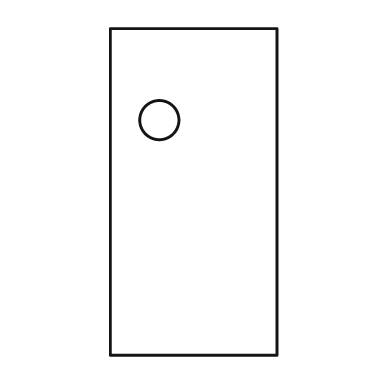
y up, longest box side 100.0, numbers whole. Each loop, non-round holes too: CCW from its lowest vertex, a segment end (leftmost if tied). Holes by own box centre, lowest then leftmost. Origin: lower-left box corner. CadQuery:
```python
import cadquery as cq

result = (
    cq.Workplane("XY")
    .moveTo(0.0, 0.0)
    .lineTo(51.0, 0.0)
    .lineTo(51.0, 100.0)
    .lineTo(0.0, 100.0)
    .close()
    .moveTo(15.0, 72.0)
    .circle(6.0)
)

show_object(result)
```